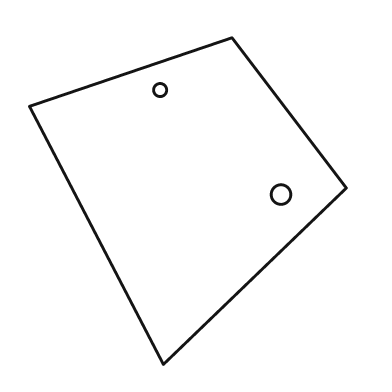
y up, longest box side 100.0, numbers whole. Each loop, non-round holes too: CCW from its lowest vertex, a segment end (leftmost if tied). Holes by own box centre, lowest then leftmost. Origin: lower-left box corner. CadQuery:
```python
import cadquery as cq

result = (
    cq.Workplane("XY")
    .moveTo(41.0, 0.0)
    .lineTo(97.0, 54.0)
    .lineTo(62.0, 100.0)
    .lineTo(0.0, 79.0)
    .close()
    .moveTo(77.0, 52.0)
    .circle(3.0)
    .moveTo(40.0, 84.0)
    .circle(2.0)
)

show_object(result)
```